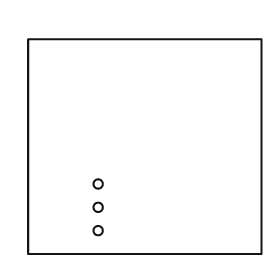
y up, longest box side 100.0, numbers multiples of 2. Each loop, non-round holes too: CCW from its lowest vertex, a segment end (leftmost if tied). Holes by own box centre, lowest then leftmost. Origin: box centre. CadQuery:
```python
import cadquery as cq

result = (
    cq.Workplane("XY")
    .moveTo(-50.0, -46.0)
    .lineTo(50.0, -46.0)
    .lineTo(50.0, 46.0)
    .lineTo(-50.0, 46.0)
    .close()
    .moveTo(-20.0, -36.0)
    .circle(2.0)
    .moveTo(-20.0, -26.0)
    .circle(2.0)
    .moveTo(-20.0, -16.0)
    .circle(2.0)
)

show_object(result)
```